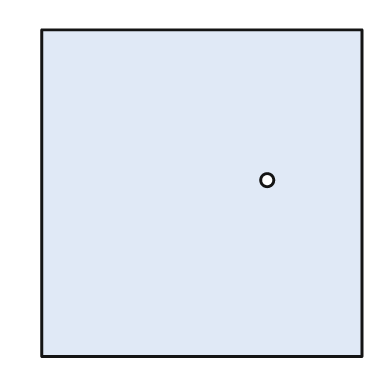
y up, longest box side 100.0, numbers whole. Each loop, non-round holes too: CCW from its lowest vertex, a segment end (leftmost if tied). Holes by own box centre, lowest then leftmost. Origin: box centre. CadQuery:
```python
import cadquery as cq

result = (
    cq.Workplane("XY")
    .moveTo(-49.0, -50.0)
    .lineTo(49.0, -50.0)
    .lineTo(49.0, 50.0)
    .lineTo(-49.0, 50.0)
    .close()
    .moveTo(20.0, 4.0)
    .circle(2.0)
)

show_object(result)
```